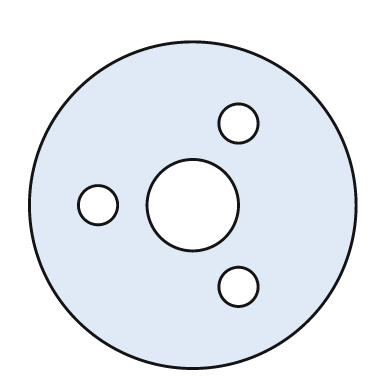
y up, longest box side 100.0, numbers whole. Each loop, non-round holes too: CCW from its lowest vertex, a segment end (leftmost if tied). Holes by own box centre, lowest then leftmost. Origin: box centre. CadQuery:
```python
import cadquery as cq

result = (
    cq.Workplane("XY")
    .moveTo(0.0, 0.0)
    .circle(50.0)
    .moveTo(14.0, -25.0)
    .circle(6.0)
    .moveTo(-29.0, 0.0)
    .circle(6.0)
    .moveTo(0.0, 0.0)
    .circle(14.0)
    .moveTo(14.0, 25.0)
    .circle(6.0)
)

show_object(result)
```